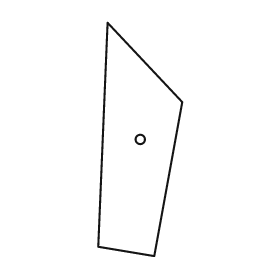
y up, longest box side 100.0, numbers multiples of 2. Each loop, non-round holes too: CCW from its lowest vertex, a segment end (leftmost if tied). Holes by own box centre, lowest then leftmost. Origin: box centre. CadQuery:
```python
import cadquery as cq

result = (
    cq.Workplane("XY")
    .moveTo(6.0, -50.0)
    .lineTo(18.0, 16.0)
    .lineTo(-14.0, 50.0)
    .lineTo(-18.0, -46.0)
    .close()
    .moveTo(0.0, 0.0)
    .circle(2.0)
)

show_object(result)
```